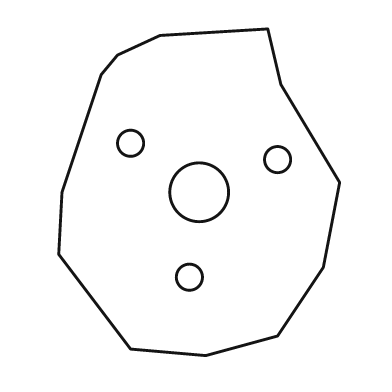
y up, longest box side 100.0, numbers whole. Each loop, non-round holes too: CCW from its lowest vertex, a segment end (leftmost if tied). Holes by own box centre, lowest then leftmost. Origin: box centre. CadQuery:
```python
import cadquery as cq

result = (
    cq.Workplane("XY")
    .moveTo(2.0, -50.0)
    .lineTo(24.0, -44.0)
    .lineTo(38.0, -23.0)
    .lineTo(43.0, 3.0)
    .lineTo(25.0, 33.0)
    .lineTo(21.0, 50.0)
    .lineTo(-12.0, 48.0)
    .lineTo(-25.0, 42.0)
    .lineTo(-30.0, 36.0)
    .lineTo(-42.0, 0.0)
    .lineTo(-43.0, -19.0)
    .lineTo(-21.0, -48.0)
    .close()
    .moveTo(-3.0, -26.0)
    .circle(4.0)
    .moveTo(0.0, 0.0)
    .circle(9.0)
    .moveTo(24.0, 10.0)
    .circle(4.0)
    .moveTo(-21.0, 15.0)
    .circle(4.0)
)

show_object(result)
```